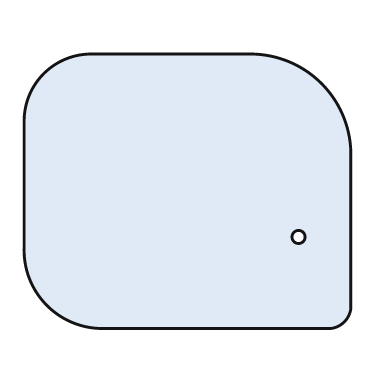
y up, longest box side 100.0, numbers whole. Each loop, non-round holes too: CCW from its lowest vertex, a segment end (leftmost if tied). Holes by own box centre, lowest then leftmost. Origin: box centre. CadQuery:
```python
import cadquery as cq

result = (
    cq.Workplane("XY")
    .moveTo(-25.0, -42.0)
    .lineTo(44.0, -42.0)
    .threePointArc((48.0, -40.0), (50.0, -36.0))
    .lineTo(50.0, 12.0)
    .threePointArc((41.0, 33.0), (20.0, 42.0))
    .lineTo(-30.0, 42.0)
    .threePointArc((-44.0, 36.0), (-50.0, 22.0))
    .lineTo(-50.0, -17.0)
    .threePointArc((-43.0, -35.0), (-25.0, -42.0))
    .close()
    .moveTo(34.0, -14.0)
    .circle(2.0)
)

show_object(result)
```